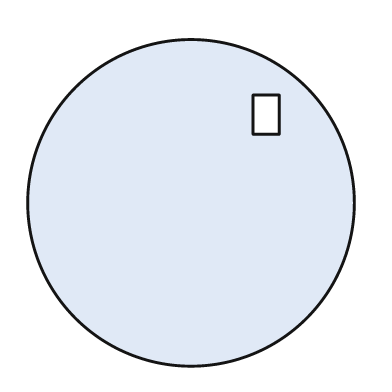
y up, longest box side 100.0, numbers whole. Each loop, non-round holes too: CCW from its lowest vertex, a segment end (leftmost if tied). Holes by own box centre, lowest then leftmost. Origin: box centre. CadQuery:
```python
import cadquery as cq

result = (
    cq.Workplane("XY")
    .moveTo(0.0, 0.0)
    .circle(50.0)
    .moveTo(19.0, 21.0)
    .lineTo(27.0, 21.0)
    .lineTo(27.0, 33.0)
    .lineTo(19.0, 33.0)
    .close()
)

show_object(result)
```